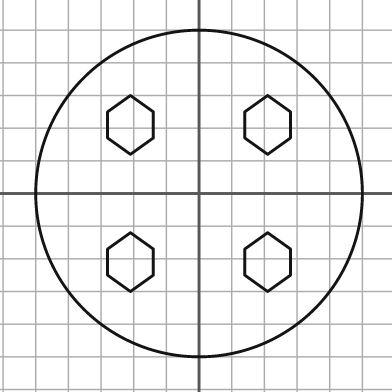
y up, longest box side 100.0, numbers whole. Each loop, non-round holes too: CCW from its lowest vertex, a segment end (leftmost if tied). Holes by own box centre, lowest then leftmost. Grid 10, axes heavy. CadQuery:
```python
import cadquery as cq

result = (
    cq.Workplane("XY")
    .moveTo(0.0, 0.0)
    .circle(50.0)
    .moveTo(-21.0, -30.0)
    .lineTo(-14.0, -25.0)
    .lineTo(-14.0, -17.0)
    .lineTo(-21.0, -12.0)
    .lineTo(-28.0, -17.0)
    .lineTo(-28.0, -25.0)
    .close()
    .moveTo(21.0, -30.0)
    .lineTo(28.0, -25.0)
    .lineTo(28.0, -17.0)
    .lineTo(21.0, -12.0)
    .lineTo(14.0, -17.0)
    .lineTo(14.0, -25.0)
    .close()
    .moveTo(-21.0, 12.0)
    .lineTo(-14.0, 17.0)
    .lineTo(-14.0, 25.0)
    .lineTo(-21.0, 30.0)
    .lineTo(-28.0, 25.0)
    .lineTo(-28.0, 17.0)
    .close()
    .moveTo(21.0, 12.0)
    .lineTo(28.0, 17.0)
    .lineTo(28.0, 25.0)
    .lineTo(21.0, 30.0)
    .lineTo(14.0, 25.0)
    .lineTo(14.0, 17.0)
    .close()
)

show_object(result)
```